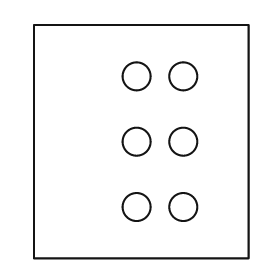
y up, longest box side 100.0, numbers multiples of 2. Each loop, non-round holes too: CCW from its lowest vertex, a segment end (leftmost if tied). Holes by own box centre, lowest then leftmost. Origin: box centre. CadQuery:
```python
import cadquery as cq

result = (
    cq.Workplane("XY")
    .moveTo(-46.0, -50.0)
    .lineTo(46.0, -50.0)
    .lineTo(46.0, 50.0)
    .lineTo(-46.0, 50.0)
    .close()
    .moveTo(-2.0, -28.0)
    .circle(6.0)
    .moveTo(18.0, -28.0)
    .circle(6.0)
    .moveTo(-2.0, 0.0)
    .circle(6.0)
    .moveTo(18.0, 0.0)
    .circle(6.0)
    .moveTo(-2.0, 28.0)
    .circle(6.0)
    .moveTo(18.0, 28.0)
    .circle(6.0)
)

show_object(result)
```